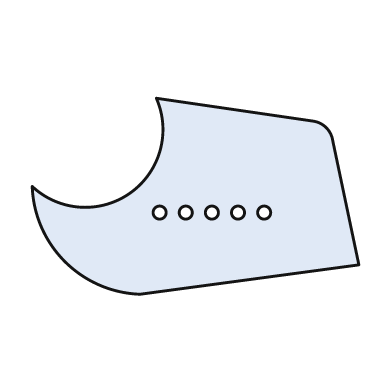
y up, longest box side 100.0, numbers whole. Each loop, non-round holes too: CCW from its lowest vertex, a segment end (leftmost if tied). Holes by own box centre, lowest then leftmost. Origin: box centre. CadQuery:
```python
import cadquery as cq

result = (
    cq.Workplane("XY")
    .moveTo(-17.0, -30.0)
    .lineTo(50.0, -21.0)
    .lineTo(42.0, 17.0)
    .threePointArc((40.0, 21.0), (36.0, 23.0))
    .lineTo(-12.0, 30.0)
    .threePointArc((-20.0, 1.0), (-50.0, 3.0))
    .threePointArc((-40.0, -20.0), (-17.0, -30.0))
    .close()
    .moveTo(-11.0, -5.0)
    .circle(2.0)
    .moveTo(-3.0, -5.0)
    .circle(2.0)
    .moveTo(5.0, -5.0)
    .circle(2.0)
    .moveTo(13.0, -5.0)
    .circle(2.0)
    .moveTo(21.0, -5.0)
    .circle(2.0)
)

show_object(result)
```